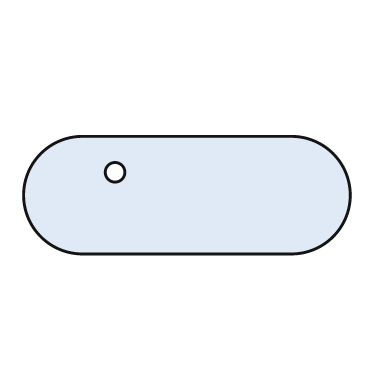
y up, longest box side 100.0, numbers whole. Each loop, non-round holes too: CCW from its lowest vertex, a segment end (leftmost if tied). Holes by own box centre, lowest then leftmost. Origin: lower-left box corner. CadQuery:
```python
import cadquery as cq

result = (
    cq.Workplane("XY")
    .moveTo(18.0, 0.0)
    .lineTo(82.0, 0.0)
    .threePointArc((100.0, 18.0), (82.0, 36.0))
    .lineTo(18.0, 36.0)
    .threePointArc((0.0, 18.0), (18.0, 0.0))
    .close()
    .moveTo(28.0, 25.0)
    .circle(3.0)
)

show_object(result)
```